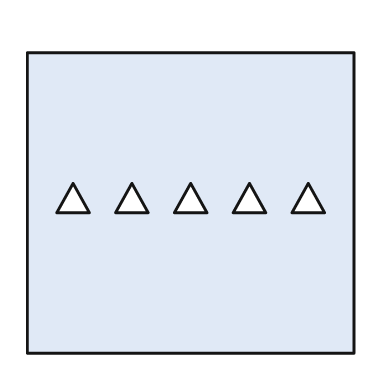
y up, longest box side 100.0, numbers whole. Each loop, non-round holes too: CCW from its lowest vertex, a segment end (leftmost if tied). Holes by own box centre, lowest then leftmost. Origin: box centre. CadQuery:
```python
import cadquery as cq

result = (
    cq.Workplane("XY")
    .moveTo(-50.0, -46.0)
    .lineTo(50.0, -46.0)
    .lineTo(50.0, 46.0)
    .lineTo(-50.0, 46.0)
    .close()
    .moveTo(-41.0, -3.0)
    .lineTo(-31.0, -3.0)
    .lineTo(-36.0, 6.0)
    .close()
    .moveTo(-23.0, -3.0)
    .lineTo(-13.0, -3.0)
    .lineTo(-18.0, 6.0)
    .close()
    .moveTo(-5.0, -3.0)
    .lineTo(5.0, -3.0)
    .lineTo(0.0, 6.0)
    .close()
    .moveTo(13.0, -3.0)
    .lineTo(23.0, -3.0)
    .lineTo(18.0, 6.0)
    .close()
    .moveTo(31.0, -3.0)
    .lineTo(41.0, -3.0)
    .lineTo(36.0, 6.0)
    .close()
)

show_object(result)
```